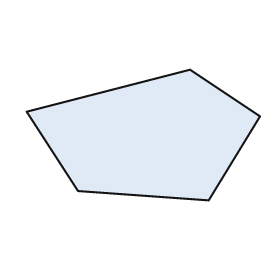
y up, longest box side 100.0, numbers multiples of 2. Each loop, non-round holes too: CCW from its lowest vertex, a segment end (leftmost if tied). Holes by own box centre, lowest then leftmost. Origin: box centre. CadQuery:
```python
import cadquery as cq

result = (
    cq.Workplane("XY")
    .moveTo(28.0, -28.0)
    .lineTo(50.0, 8.0)
    .lineTo(20.0, 28.0)
    .lineTo(-50.0, 10.0)
    .lineTo(-28.0, -24.0)
    .close()
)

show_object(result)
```